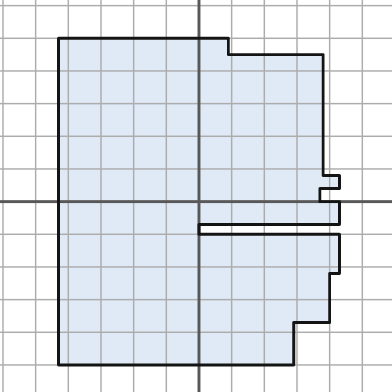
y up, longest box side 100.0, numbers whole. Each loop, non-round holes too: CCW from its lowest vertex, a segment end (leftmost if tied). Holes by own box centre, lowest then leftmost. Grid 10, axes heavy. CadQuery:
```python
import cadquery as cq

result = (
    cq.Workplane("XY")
    .moveTo(-43.0, -50.0)
    .lineTo(29.0, -50.0)
    .lineTo(29.0, -37.0)
    .lineTo(40.0, -37.0)
    .lineTo(40.0, -22.0)
    .lineTo(43.0, -22.0)
    .lineTo(43.0, -10.0)
    .lineTo(0.0, -10.0)
    .lineTo(0.0, -7.0)
    .lineTo(43.0, -7.0)
    .lineTo(43.0, 0.0)
    .lineTo(37.0, 0.0)
    .lineTo(37.0, 4.0)
    .lineTo(43.0, 4.0)
    .lineTo(43.0, 8.0)
    .lineTo(38.0, 8.0)
    .lineTo(38.0, 45.0)
    .lineTo(9.0, 45.0)
    .lineTo(9.0, 50.0)
    .lineTo(-43.0, 50.0)
    .close()
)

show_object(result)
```